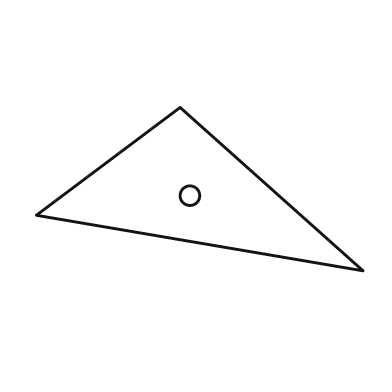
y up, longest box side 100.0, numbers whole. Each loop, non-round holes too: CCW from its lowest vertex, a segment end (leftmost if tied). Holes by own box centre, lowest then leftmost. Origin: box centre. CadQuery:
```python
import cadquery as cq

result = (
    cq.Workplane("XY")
    .moveTo(50.0, -25.0)
    .lineTo(-6.0, 25.0)
    .lineTo(-50.0, -8.0)
    .close()
    .moveTo(-3.0, -2.0)
    .circle(3.0)
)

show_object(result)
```